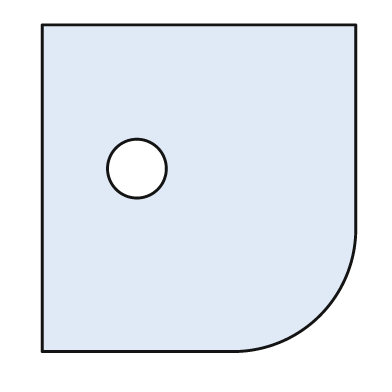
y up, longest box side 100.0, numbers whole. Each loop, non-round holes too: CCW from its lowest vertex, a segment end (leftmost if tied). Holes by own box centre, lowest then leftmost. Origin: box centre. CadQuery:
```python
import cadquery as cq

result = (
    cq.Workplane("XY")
    .moveTo(-48.0, -50.0)
    .lineTo(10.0, -50.0)
    .threePointArc((37.0, -39.0), (48.0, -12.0))
    .lineTo(48.0, 50.0)
    .lineTo(-48.0, 50.0)
    .close()
    .moveTo(-19.0, 6.0)
    .circle(9.0)
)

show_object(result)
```